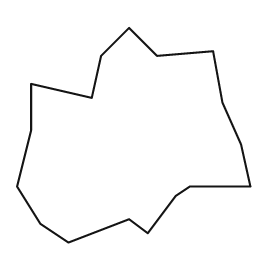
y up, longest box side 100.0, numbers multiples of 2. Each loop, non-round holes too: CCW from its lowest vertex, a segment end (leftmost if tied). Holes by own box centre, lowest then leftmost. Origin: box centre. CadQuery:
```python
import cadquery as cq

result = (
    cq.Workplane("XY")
    .moveTo(-28.0, -46.0)
    .lineTo(-2.0, -36.0)
    .lineTo(6.0, -42.0)
    .lineTo(18.0, -26.0)
    .lineTo(24.0, -22.0)
    .lineTo(50.0, -22.0)
    .lineTo(46.0, -4.0)
    .lineTo(38.0, 14.0)
    .lineTo(34.0, 36.0)
    .lineTo(10.0, 34.0)
    .lineTo(-2.0, 46.0)
    .lineTo(-14.0, 34.0)
    .lineTo(-18.0, 16.0)
    .lineTo(-44.0, 22.0)
    .lineTo(-44.0, 2.0)
    .lineTo(-50.0, -22.0)
    .lineTo(-40.0, -38.0)
    .close()
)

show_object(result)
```